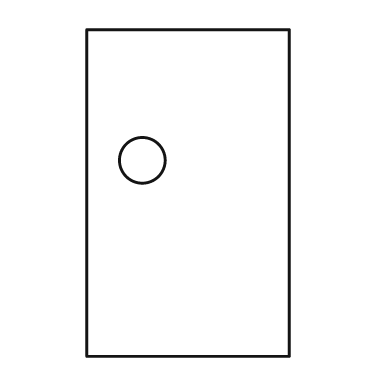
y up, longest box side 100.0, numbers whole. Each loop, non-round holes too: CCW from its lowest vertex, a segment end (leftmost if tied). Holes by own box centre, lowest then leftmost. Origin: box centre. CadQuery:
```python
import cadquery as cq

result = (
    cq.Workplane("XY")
    .moveTo(-31.0, -50.0)
    .lineTo(31.0, -50.0)
    .lineTo(31.0, 50.0)
    .lineTo(-31.0, 50.0)
    .close()
    .moveTo(-14.0, 10.0)
    .circle(7.0)
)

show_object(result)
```